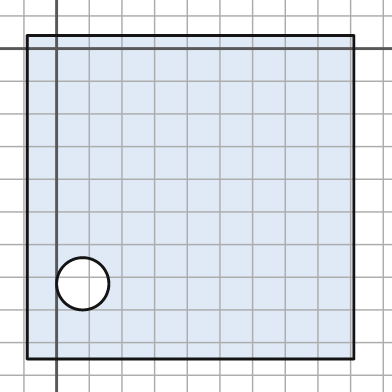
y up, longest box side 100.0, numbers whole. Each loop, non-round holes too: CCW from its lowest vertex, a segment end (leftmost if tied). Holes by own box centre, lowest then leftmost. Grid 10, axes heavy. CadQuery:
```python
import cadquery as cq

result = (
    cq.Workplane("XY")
    .moveTo(-9.0, -95.0)
    .lineTo(91.0, -95.0)
    .lineTo(91.0, 4.0)
    .lineTo(-9.0, 4.0)
    .close()
    .moveTo(8.0, -72.0)
    .circle(8.0)
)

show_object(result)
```